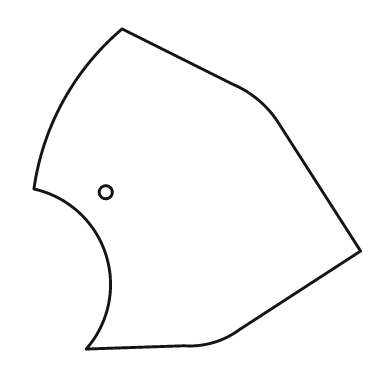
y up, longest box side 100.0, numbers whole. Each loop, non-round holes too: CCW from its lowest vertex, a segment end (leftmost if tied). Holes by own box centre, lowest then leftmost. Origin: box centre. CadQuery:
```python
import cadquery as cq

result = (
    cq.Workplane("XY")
    .moveTo(-34.0, -49.0)
    .lineTo(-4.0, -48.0)
    .threePointArc((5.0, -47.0), (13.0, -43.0))
    .lineTo(50.0, -19.0)
    .lineTo(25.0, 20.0)
    .threePointArc((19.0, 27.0), (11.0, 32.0))
    .lineTo(-23.0, 49.0)
    .threePointArc((-41.0, 27.0), (-50.0, 0.0))
    .threePointArc((-28.0, -20.0), (-34.0, -49.0))
    .close()
    .moveTo(-28.0, -1.0)
    .circle(2.0)
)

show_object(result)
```